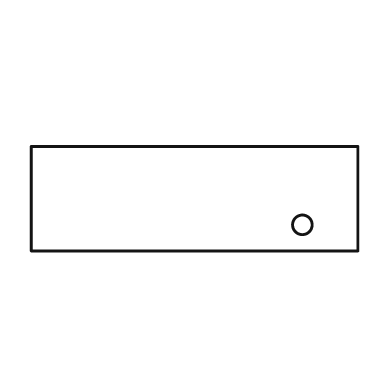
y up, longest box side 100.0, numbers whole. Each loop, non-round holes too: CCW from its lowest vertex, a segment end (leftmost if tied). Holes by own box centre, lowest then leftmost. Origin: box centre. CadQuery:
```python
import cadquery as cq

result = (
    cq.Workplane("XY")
    .moveTo(-50.0, -16.0)
    .lineTo(50.0, -16.0)
    .lineTo(50.0, 16.0)
    .lineTo(-50.0, 16.0)
    .close()
    .moveTo(33.0, -8.0)
    .circle(3.0)
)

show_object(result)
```